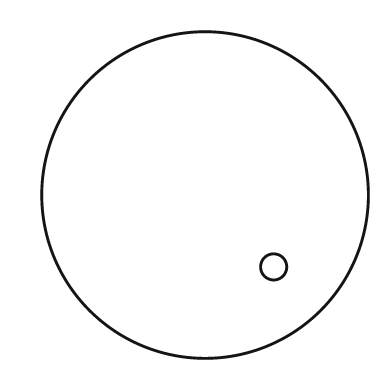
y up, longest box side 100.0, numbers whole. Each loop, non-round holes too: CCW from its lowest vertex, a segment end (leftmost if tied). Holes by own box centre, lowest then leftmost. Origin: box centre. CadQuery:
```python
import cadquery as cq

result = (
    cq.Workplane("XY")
    .moveTo(0.0, 0.0)
    .circle(50.0)
    .moveTo(21.0, -22.0)
    .circle(4.0)
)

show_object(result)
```